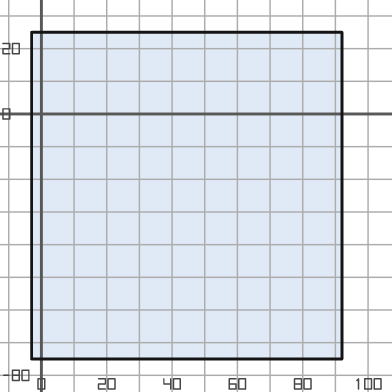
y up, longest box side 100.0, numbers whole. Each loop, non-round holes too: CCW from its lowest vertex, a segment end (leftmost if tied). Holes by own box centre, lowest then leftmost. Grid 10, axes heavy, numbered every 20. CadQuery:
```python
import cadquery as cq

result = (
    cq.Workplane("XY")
    .moveTo(-3.0, -75.0)
    .lineTo(92.0, -75.0)
    .lineTo(92.0, 25.0)
    .lineTo(-3.0, 25.0)
    .close()
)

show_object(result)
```